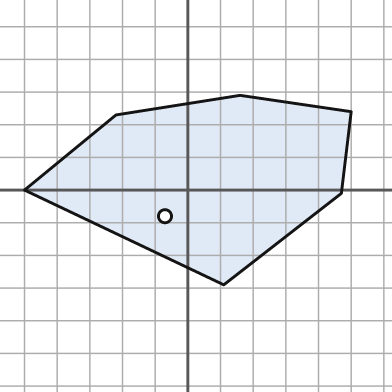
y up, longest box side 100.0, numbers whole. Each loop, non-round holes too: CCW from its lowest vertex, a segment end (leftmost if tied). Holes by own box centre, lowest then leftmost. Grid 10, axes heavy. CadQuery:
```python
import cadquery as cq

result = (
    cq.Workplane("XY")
    .moveTo(11.0, -29.0)
    .lineTo(47.0, -1.0)
    .lineTo(50.0, 24.0)
    .lineTo(16.0, 29.0)
    .lineTo(-22.0, 23.0)
    .lineTo(-50.0, 0.0)
    .close()
    .moveTo(-7.0, -8.0)
    .circle(2.0)
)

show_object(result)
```